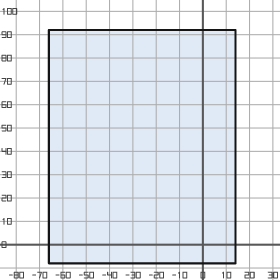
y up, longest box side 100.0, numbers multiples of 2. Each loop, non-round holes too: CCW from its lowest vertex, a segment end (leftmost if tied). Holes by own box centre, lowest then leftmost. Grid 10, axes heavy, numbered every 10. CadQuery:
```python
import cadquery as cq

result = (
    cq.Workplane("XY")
    .moveTo(-66.0, -8.0)
    .lineTo(14.0, -8.0)
    .lineTo(14.0, 92.0)
    .lineTo(-66.0, 92.0)
    .close()
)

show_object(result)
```